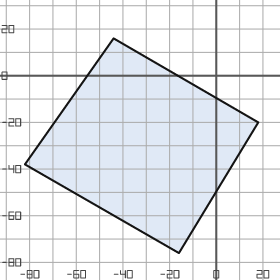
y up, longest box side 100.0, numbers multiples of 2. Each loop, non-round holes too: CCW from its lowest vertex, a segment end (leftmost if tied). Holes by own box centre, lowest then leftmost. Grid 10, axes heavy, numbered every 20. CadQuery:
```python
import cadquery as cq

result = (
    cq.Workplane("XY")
    .moveTo(-16.0, -76.0)
    .lineTo(18.0, -20.0)
    .lineTo(-44.0, 16.0)
    .lineTo(-82.0, -38.0)
    .close()
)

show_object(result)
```